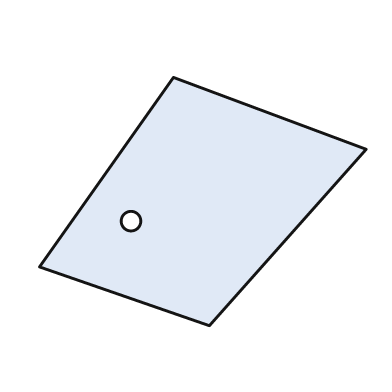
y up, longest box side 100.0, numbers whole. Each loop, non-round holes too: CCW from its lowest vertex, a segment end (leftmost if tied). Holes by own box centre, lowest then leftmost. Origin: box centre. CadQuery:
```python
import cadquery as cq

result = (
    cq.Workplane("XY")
    .moveTo(2.0, -38.0)
    .lineTo(50.0, 16.0)
    .lineTo(-9.0, 38.0)
    .lineTo(-50.0, -20.0)
    .close()
    .moveTo(-22.0, -6.0)
    .circle(3.0)
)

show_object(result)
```